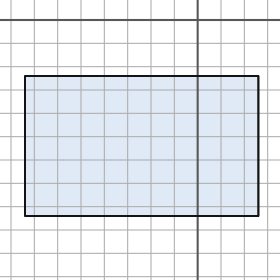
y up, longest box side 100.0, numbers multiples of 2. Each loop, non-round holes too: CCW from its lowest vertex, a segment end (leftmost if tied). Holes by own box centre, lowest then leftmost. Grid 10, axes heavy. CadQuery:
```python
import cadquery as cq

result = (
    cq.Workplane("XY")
    .moveTo(-74.0, -84.0)
    .lineTo(26.0, -84.0)
    .lineTo(26.0, -24.0)
    .lineTo(-74.0, -24.0)
    .close()
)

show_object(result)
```